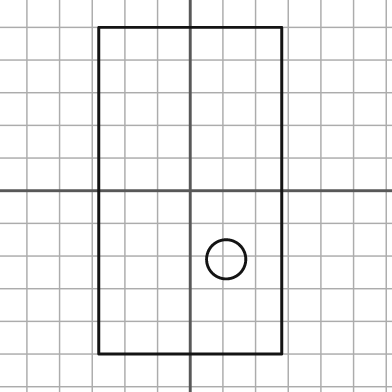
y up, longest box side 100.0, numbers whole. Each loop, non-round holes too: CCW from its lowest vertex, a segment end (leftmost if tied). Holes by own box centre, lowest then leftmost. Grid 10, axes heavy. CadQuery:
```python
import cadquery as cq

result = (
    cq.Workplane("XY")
    .moveTo(-28.0, -50.0)
    .lineTo(28.0, -50.0)
    .lineTo(28.0, 50.0)
    .lineTo(-28.0, 50.0)
    .close()
    .moveTo(11.0, -21.0)
    .circle(6.0)
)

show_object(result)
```